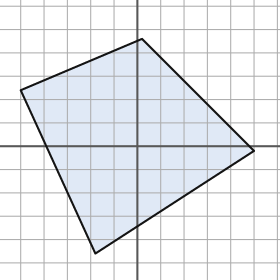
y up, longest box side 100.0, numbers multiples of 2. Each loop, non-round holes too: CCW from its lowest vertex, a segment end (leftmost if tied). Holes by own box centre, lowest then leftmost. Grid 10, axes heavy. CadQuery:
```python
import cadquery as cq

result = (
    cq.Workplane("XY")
    .moveTo(-18.0, -46.0)
    .lineTo(50.0, -2.0)
    .lineTo(2.0, 46.0)
    .lineTo(-50.0, 24.0)
    .close()
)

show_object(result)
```